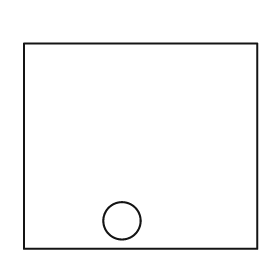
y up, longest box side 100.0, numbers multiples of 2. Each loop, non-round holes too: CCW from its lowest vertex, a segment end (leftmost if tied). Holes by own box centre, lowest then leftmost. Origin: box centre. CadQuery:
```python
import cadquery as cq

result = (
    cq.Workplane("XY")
    .moveTo(-50.0, -44.0)
    .lineTo(50.0, -44.0)
    .lineTo(50.0, 44.0)
    .lineTo(-50.0, 44.0)
    .close()
    .moveTo(-8.0, -32.0)
    .circle(8.0)
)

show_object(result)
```